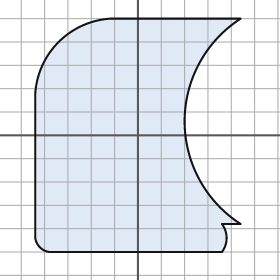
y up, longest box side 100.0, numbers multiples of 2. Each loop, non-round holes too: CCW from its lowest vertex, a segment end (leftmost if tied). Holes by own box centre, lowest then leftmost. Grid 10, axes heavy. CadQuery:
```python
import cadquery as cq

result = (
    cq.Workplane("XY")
    .moveTo(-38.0, -50.0)
    .lineTo(36.0, -50.0)
    .threePointArc((38.0, -44.0), (36.0, -38.0))
    .lineTo(44.0, -38.0)
    .threePointArc((20.0, 6.0), (44.0, 50.0))
    .lineTo(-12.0, 50.0)
    .threePointArc((-34.0, 40.0), (-44.0, 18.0))
    .lineTo(-44.0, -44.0)
    .threePointArc((-42.0, -48.0), (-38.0, -50.0))
    .close()
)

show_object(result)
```